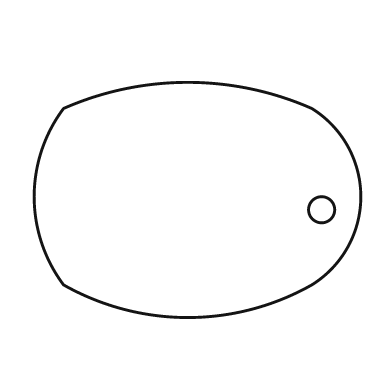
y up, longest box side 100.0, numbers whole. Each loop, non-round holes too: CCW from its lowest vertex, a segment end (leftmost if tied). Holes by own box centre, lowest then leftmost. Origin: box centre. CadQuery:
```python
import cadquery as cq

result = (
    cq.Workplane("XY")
    .moveTo(-41.0, -26.0)
    .threePointArc((-3.0, -36.0), (35.0, -26.0))
    .threePointArc((50.0, 1.0), (35.0, 28.0))
    .threePointArc((-3.0, 36.0), (-41.0, 28.0))
    .threePointArc((-50.0, 1.0), (-41.0, -26.0))
    .close()
    .moveTo(38.0, -3.0)
    .circle(4.0)
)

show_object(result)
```